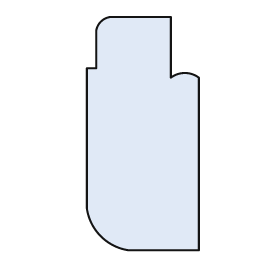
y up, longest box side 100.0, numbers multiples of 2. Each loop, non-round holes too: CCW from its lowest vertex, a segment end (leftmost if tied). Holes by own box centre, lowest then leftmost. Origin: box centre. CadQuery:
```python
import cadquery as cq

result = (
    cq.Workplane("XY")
    .moveTo(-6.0, -50.0)
    .lineTo(24.0, -50.0)
    .lineTo(24.0, 24.0)
    .threePointArc((18.0, 26.0), (12.0, 24.0))
    .lineTo(12.0, 50.0)
    .lineTo(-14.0, 50.0)
    .threePointArc((-18.0, 48.0), (-20.0, 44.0))
    .lineTo(-20.0, 28.0)
    .lineTo(-24.0, 28.0)
    .lineTo(-24.0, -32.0)
    .threePointArc((-18.0, -44.0), (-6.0, -50.0))
    .close()
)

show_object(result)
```